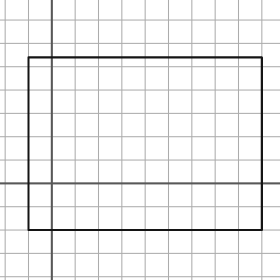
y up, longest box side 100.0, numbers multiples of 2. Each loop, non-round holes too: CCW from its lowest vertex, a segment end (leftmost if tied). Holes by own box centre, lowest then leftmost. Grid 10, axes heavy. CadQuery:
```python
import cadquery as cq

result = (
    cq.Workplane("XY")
    .moveTo(-10.0, -20.0)
    .lineTo(90.0, -20.0)
    .lineTo(90.0, 54.0)
    .lineTo(-10.0, 54.0)
    .close()
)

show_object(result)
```